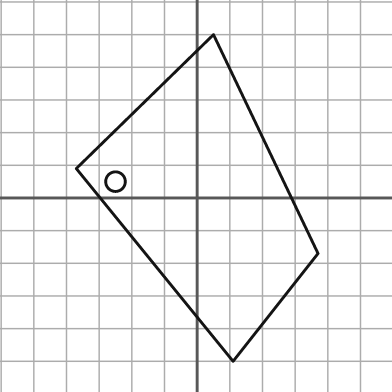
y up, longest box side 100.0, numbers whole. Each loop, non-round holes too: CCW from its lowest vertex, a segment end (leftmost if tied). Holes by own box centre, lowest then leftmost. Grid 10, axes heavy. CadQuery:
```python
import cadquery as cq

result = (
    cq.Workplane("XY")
    .moveTo(11.0, -50.0)
    .lineTo(37.0, -17.0)
    .lineTo(5.0, 50.0)
    .lineTo(-37.0, 9.0)
    .close()
    .moveTo(-25.0, 5.0)
    .circle(3.0)
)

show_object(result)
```